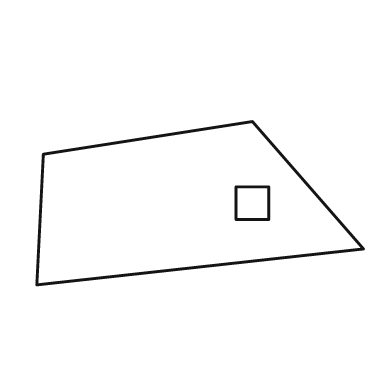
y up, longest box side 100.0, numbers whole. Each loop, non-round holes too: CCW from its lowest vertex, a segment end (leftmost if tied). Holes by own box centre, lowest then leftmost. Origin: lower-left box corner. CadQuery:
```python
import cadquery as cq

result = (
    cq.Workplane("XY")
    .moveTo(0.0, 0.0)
    .lineTo(100.0, 11.0)
    .lineTo(66.0, 50.0)
    .lineTo(2.0, 40.0)
    .close()
    .moveTo(61.0, 20.0)
    .lineTo(71.0, 20.0)
    .lineTo(71.0, 30.0)
    .lineTo(61.0, 30.0)
    .close()
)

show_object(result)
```